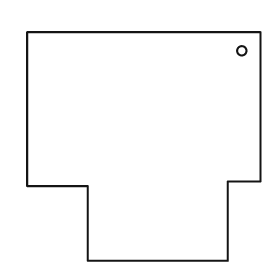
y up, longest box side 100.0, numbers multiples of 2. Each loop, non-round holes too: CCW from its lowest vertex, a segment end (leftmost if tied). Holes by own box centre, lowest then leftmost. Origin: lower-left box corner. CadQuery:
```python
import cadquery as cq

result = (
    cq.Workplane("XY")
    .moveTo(26.0, 0.0)
    .lineTo(86.0, 0.0)
    .lineTo(86.0, 34.0)
    .lineTo(100.0, 34.0)
    .lineTo(100.0, 98.0)
    .lineTo(0.0, 98.0)
    .lineTo(0.0, 32.0)
    .lineTo(26.0, 32.0)
    .close()
    .moveTo(92.0, 90.0)
    .circle(2.0)
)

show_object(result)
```